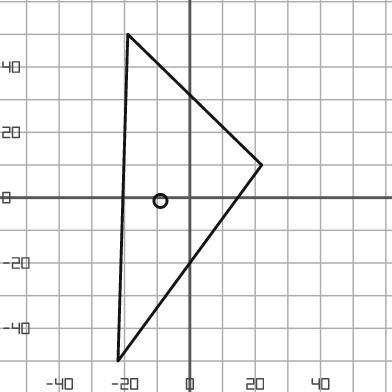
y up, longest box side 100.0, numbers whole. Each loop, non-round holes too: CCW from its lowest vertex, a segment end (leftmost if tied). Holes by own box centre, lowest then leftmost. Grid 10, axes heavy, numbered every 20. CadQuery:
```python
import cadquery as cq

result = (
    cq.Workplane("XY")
    .moveTo(-22.0, -50.0)
    .lineTo(22.0, 10.0)
    .lineTo(-19.0, 50.0)
    .close()
    .moveTo(-9.0, -1.0)
    .circle(2.0)
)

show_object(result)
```